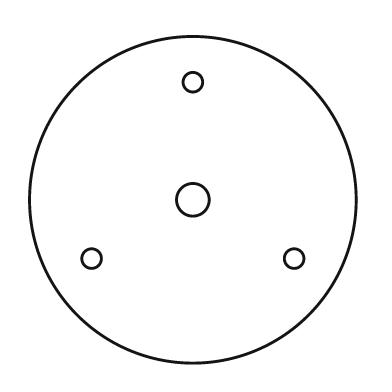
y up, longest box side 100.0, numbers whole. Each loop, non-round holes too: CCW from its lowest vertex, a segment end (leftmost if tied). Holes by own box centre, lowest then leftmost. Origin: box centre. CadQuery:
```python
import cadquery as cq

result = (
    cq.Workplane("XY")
    .moveTo(0.0, 0.0)
    .circle(50.0)
    .moveTo(-31.0, -18.0)
    .circle(3.0)
    .moveTo(31.0, -18.0)
    .circle(3.0)
    .moveTo(0.0, 0.0)
    .circle(5.0)
    .moveTo(0.0, 36.0)
    .circle(3.0)
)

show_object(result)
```